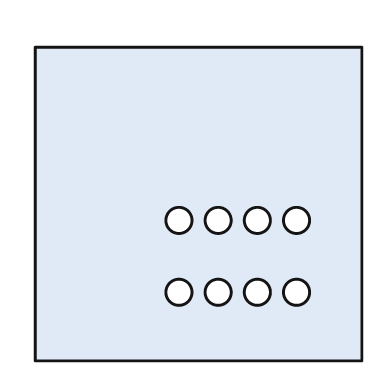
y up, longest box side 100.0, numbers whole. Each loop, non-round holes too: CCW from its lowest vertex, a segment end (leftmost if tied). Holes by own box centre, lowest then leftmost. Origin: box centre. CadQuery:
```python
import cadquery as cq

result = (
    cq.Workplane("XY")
    .moveTo(-50.0, -48.0)
    .lineTo(50.0, -48.0)
    .lineTo(50.0, 48.0)
    .lineTo(-50.0, 48.0)
    .close()
    .moveTo(-6.0, -27.0)
    .circle(4.0)
    .moveTo(6.0, -27.0)
    .circle(4.0)
    .moveTo(18.0, -27.0)
    .circle(4.0)
    .moveTo(30.0, -27.0)
    .circle(4.0)
    .moveTo(-6.0, -5.0)
    .circle(4.0)
    .moveTo(6.0, -5.0)
    .circle(4.0)
    .moveTo(18.0, -5.0)
    .circle(4.0)
    .moveTo(30.0, -5.0)
    .circle(4.0)
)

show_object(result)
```